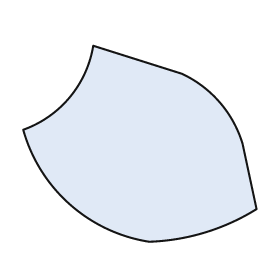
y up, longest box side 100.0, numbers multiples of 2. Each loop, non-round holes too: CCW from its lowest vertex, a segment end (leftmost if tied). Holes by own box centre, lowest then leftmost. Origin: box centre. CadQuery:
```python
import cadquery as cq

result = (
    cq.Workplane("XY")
    .moveTo(4.0, -42.0)
    .threePointArc((28.0, -38.0), (50.0, -28.0))
    .lineTo(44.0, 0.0)
    .threePointArc((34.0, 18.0), (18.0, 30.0))
    .lineTo(-20.0, 42.0)
    .threePointArc((-30.0, 20.0), (-50.0, 6.0))
    .threePointArc((-30.0, -26.0), (4.0, -42.0))
    .close()
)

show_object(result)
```